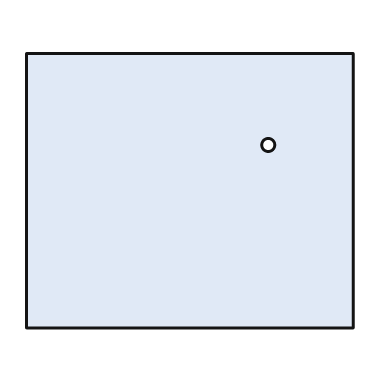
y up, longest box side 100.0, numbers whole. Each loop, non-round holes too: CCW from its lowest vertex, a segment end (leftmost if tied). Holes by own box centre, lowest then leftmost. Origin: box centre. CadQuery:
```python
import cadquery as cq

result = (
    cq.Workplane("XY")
    .moveTo(-50.0, -42.0)
    .lineTo(50.0, -42.0)
    .lineTo(50.0, 42.0)
    .lineTo(-50.0, 42.0)
    .close()
    .moveTo(24.0, 14.0)
    .circle(2.0)
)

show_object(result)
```